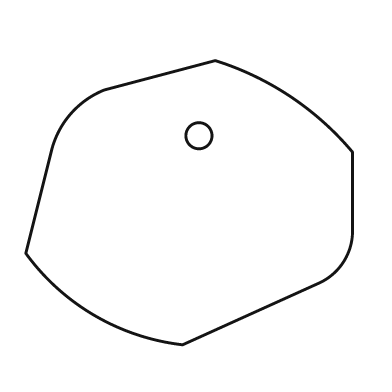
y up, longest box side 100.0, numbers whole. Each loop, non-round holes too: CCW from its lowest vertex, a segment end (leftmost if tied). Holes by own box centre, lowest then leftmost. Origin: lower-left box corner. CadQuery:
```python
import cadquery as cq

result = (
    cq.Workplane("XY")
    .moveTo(48.0, 0.0)
    .lineTo(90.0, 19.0)
    .threePointArc((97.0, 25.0), (100.0, 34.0))
    .lineTo(100.0, 59.0)
    .threePointArc((81.0, 76.0), (58.0, 87.0))
    .lineTo(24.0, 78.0)
    .threePointArc((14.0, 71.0), (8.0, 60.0))
    .lineTo(0.0, 28.0)
    .threePointArc((21.0, 9.0), (48.0, 0.0))
    .close()
    .moveTo(53.0, 64.0)
    .circle(4.0)
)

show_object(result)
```